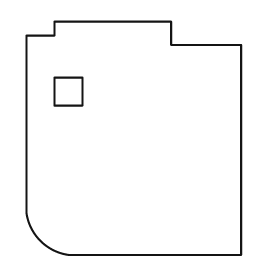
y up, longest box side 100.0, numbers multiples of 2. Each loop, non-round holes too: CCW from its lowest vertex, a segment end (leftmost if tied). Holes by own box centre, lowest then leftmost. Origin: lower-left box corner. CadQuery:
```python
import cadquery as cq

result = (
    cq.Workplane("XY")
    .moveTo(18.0, 0.0)
    .lineTo(92.0, 0.0)
    .lineTo(92.0, 90.0)
    .lineTo(62.0, 90.0)
    .lineTo(62.0, 100.0)
    .lineTo(12.0, 100.0)
    .lineTo(12.0, 94.0)
    .lineTo(0.0, 94.0)
    .lineTo(0.0, 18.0)
    .threePointArc((6.0, 6.0), (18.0, 0.0))
    .close()
    .moveTo(12.0, 64.0)
    .lineTo(24.0, 64.0)
    .lineTo(24.0, 76.0)
    .lineTo(12.0, 76.0)
    .close()
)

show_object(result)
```